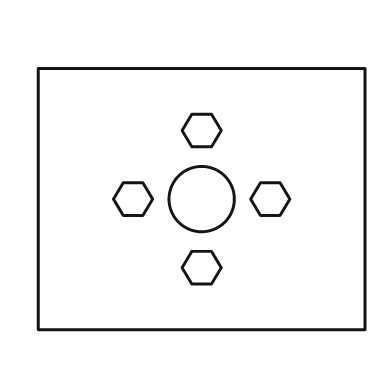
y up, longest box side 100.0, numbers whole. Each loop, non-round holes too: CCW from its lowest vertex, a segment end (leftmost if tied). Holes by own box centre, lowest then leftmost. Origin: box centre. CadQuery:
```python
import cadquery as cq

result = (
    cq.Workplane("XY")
    .moveTo(-50.0, -40.0)
    .lineTo(50.0, -40.0)
    .lineTo(50.0, 40.0)
    .lineTo(-50.0, 40.0)
    .close()
    .moveTo(-3.0, -26.0)
    .lineTo(3.0, -26.0)
    .lineTo(6.0, -21.0)
    .lineTo(3.0, -16.0)
    .lineTo(-3.0, -16.0)
    .lineTo(-6.0, -21.0)
    .close()
    .moveTo(-24.0, -5.0)
    .lineTo(-18.0, -5.0)
    .lineTo(-15.0, 0.0)
    .lineTo(-18.0, 5.0)
    .lineTo(-24.0, 5.0)
    .lineTo(-27.0, 0.0)
    .close()
    .moveTo(0.0, 0.0)
    .circle(10.0)
    .moveTo(18.0, -5.0)
    .lineTo(24.0, -5.0)
    .lineTo(27.0, 0.0)
    .lineTo(24.0, 5.0)
    .lineTo(18.0, 5.0)
    .lineTo(15.0, 0.0)
    .close()
    .moveTo(-3.0, 16.0)
    .lineTo(3.0, 16.0)
    .lineTo(6.0, 21.0)
    .lineTo(3.0, 26.0)
    .lineTo(-3.0, 26.0)
    .lineTo(-6.0, 21.0)
    .close()
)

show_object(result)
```